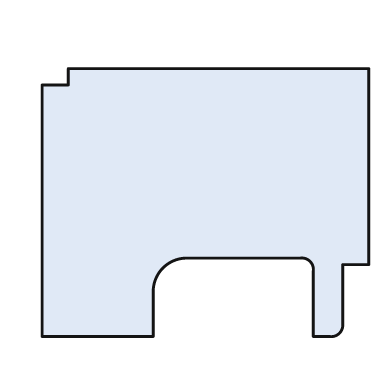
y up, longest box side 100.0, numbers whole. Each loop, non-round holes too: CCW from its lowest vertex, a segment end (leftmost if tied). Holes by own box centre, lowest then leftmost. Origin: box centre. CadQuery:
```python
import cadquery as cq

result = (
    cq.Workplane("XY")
    .moveTo(-50.0, -41.0)
    .lineTo(-16.0, -41.0)
    .lineTo(-16.0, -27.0)
    .threePointArc((-13.0, -20.0), (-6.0, -17.0))
    .lineTo(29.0, -17.0)
    .threePointArc((32.0, -18.0), (33.0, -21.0))
    .lineTo(33.0, -41.0)
    .lineTo(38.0, -41.0)
    .threePointArc((41.0, -40.0), (42.0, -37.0))
    .lineTo(42.0, -19.0)
    .lineTo(50.0, -19.0)
    .lineTo(50.0, 41.0)
    .lineTo(-42.0, 41.0)
    .lineTo(-42.0, 36.0)
    .lineTo(-50.0, 36.0)
    .close()
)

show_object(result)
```